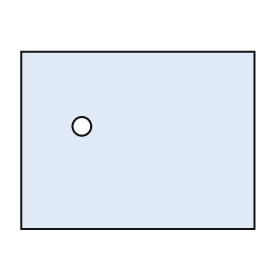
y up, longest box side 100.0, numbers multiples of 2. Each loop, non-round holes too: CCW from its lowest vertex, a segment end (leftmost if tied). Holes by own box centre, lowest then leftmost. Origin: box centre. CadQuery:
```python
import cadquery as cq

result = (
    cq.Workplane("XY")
    .moveTo(-50.0, -38.0)
    .lineTo(50.0, -38.0)
    .lineTo(50.0, 38.0)
    .lineTo(-50.0, 38.0)
    .close()
    .moveTo(-24.0, 6.0)
    .circle(4.0)
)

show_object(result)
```